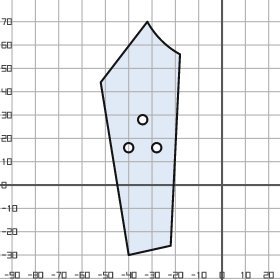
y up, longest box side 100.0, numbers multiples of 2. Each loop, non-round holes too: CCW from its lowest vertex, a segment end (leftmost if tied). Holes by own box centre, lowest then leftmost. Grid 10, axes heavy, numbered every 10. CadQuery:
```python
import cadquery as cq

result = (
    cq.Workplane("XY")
    .moveTo(-40.0, -30.0)
    .lineTo(-22.0, -26.0)
    .lineTo(-18.0, 56.0)
    .threePointArc((-26.0, 62.0), (-32.0, 70.0))
    .lineTo(-52.0, 44.0)
    .close()
    .moveTo(-40.0, 16.0)
    .circle(2.0)
    .moveTo(-28.0, 16.0)
    .circle(2.0)
    .moveTo(-34.0, 28.0)
    .circle(2.0)
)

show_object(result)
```